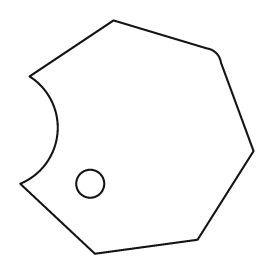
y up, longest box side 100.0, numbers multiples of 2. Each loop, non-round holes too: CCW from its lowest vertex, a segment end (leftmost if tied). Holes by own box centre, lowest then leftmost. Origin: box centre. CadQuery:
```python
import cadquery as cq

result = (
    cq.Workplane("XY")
    .moveTo(-18.0, -50.0)
    .lineTo(26.0, -44.0)
    .lineTo(50.0, -6.0)
    .lineTo(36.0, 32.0)
    .threePointArc((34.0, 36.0), (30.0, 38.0))
    .lineTo(-10.0, 50.0)
    .lineTo(-46.0, 26.0)
    .threePointArc((-34.0, 2.0), (-50.0, -20.0))
    .close()
    .moveTo(-20.0, -20.0)
    .circle(6.0)
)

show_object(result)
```